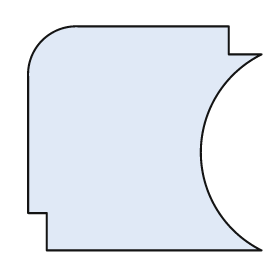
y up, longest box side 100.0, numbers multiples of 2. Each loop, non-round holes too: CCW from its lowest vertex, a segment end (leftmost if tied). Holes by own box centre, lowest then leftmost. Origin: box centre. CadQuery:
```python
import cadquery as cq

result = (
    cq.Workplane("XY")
    .moveTo(-42.0, -48.0)
    .lineTo(50.0, -48.0)
    .threePointArc((24.0, -6.0), (50.0, 36.0))
    .lineTo(36.0, 36.0)
    .lineTo(36.0, 48.0)
    .lineTo(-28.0, 48.0)
    .threePointArc((-44.0, 42.0), (-50.0, 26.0))
    .lineTo(-50.0, -32.0)
    .lineTo(-42.0, -32.0)
    .close()
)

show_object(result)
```